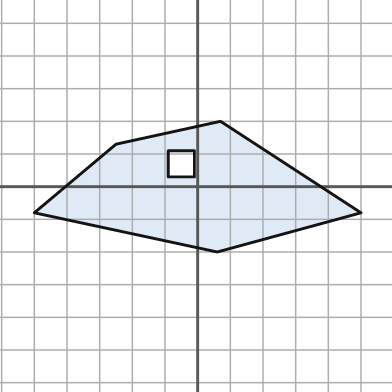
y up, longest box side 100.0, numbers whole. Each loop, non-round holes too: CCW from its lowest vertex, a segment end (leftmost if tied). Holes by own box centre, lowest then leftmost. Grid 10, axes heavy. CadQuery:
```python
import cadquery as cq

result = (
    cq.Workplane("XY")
    .moveTo(6.0, -20.0)
    .lineTo(50.0, -8.0)
    .lineTo(7.0, 20.0)
    .lineTo(-25.0, 13.0)
    .lineTo(-50.0, -8.0)
    .close()
    .moveTo(-9.0, 3.0)
    .lineTo(-1.0, 3.0)
    .lineTo(-1.0, 11.0)
    .lineTo(-9.0, 11.0)
    .close()
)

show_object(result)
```